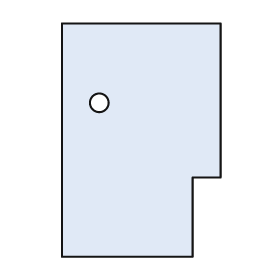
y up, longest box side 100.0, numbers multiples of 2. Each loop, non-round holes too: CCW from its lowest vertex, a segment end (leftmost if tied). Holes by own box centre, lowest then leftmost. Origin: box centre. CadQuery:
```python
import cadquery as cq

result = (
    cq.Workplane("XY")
    .moveTo(-34.0, -50.0)
    .lineTo(22.0, -50.0)
    .lineTo(22.0, -16.0)
    .lineTo(34.0, -16.0)
    .lineTo(34.0, 50.0)
    .lineTo(-34.0, 50.0)
    .close()
    .moveTo(-18.0, 16.0)
    .circle(4.0)
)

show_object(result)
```